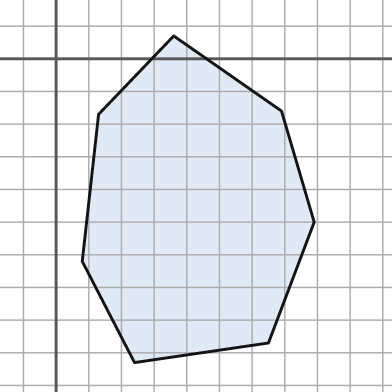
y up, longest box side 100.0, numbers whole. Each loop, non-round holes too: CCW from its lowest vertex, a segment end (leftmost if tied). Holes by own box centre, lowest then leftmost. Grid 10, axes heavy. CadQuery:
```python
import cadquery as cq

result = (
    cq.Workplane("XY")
    .moveTo(24.0, -93.0)
    .lineTo(65.0, -87.0)
    .lineTo(79.0, -50.0)
    .lineTo(69.0, -16.0)
    .lineTo(36.0, 7.0)
    .lineTo(13.0, -17.0)
    .lineTo(8.0, -62.0)
    .close()
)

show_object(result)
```